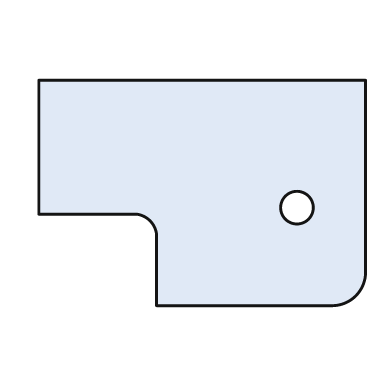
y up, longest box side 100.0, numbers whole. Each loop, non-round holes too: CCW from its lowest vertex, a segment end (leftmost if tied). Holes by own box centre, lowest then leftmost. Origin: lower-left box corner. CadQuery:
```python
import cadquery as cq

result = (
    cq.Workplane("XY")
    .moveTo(36.0, 0.0)
    .lineTo(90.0, 0.0)
    .threePointArc((97.0, 3.0), (100.0, 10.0))
    .lineTo(100.0, 69.0)
    .lineTo(0.0, 69.0)
    .lineTo(0.0, 28.0)
    .lineTo(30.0, 28.0)
    .threePointArc((34.0, 26.0), (36.0, 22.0))
    .close()
    .moveTo(79.0, 30.0)
    .circle(5.0)
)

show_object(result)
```